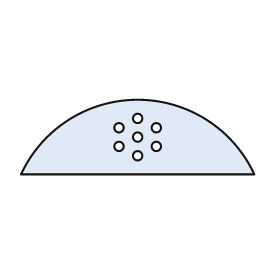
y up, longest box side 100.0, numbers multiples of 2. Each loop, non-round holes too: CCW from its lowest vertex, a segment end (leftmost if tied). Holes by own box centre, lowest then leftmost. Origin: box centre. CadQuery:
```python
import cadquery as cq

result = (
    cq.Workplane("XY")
    .moveTo(-50.0, -16.0)
    .lineTo(50.0, -16.0)
    .threePointArc((0.0, 16.0), (-50.0, -16.0))
    .close()
    .moveTo(0.0, -8.0)
    .circle(2.0)
    .moveTo(-8.0, -4.0)
    .circle(2.0)
    .moveTo(8.0, -4.0)
    .circle(2.0)
    .moveTo(0.0, 0.0)
    .circle(2.0)
    .moveTo(-8.0, 4.0)
    .circle(2.0)
    .moveTo(8.0, 4.0)
    .circle(2.0)
    .moveTo(0.0, 8.0)
    .circle(2.0)
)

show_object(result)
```